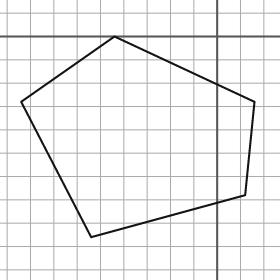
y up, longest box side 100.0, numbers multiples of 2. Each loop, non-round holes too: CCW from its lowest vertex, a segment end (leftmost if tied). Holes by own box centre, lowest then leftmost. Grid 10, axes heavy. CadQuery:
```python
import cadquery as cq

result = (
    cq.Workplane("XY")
    .moveTo(-54.0, -86.0)
    .lineTo(12.0, -68.0)
    .lineTo(16.0, -28.0)
    .lineTo(-44.0, 0.0)
    .lineTo(-84.0, -28.0)
    .close()
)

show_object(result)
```